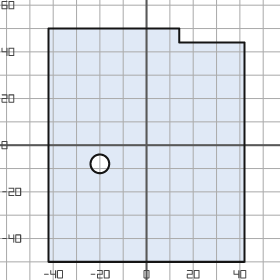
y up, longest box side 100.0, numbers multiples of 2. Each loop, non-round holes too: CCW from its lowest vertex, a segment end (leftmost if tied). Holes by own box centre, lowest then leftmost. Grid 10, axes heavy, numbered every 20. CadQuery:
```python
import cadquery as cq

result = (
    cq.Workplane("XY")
    .moveTo(-42.0, -50.0)
    .lineTo(42.0, -50.0)
    .lineTo(42.0, 44.0)
    .lineTo(14.0, 44.0)
    .lineTo(14.0, 50.0)
    .lineTo(-42.0, 50.0)
    .close()
    .moveTo(-20.0, -8.0)
    .circle(4.0)
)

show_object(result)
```